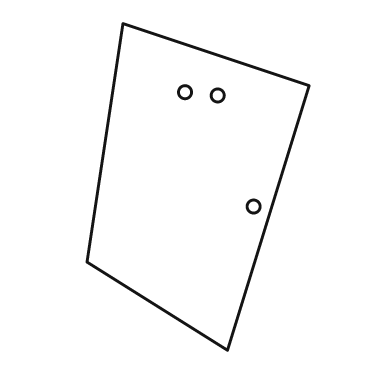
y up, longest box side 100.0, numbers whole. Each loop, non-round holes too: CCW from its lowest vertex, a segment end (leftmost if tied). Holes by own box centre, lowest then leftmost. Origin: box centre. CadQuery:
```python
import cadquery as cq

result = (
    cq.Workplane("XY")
    .moveTo(9.0, -50.0)
    .lineTo(34.0, 31.0)
    .lineTo(-23.0, 50.0)
    .lineTo(-34.0, -23.0)
    .close()
    .moveTo(17.0, -6.0)
    .circle(2.0)
    .moveTo(6.0, 28.0)
    .circle(2.0)
    .moveTo(-4.0, 29.0)
    .circle(2.0)
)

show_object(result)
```